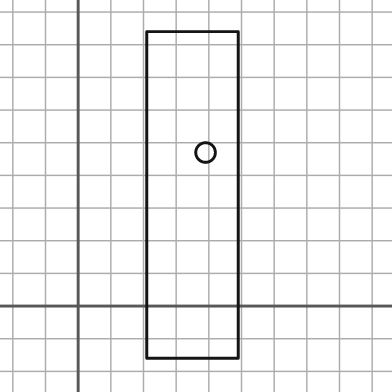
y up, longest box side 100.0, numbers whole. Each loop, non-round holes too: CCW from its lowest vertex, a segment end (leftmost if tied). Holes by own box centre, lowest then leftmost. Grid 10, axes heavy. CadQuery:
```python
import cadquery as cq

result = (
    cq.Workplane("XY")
    .moveTo(21.0, -16.0)
    .lineTo(49.0, -16.0)
    .lineTo(49.0, 84.0)
    .lineTo(21.0, 84.0)
    .close()
    .moveTo(39.0, 47.0)
    .circle(3.0)
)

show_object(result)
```